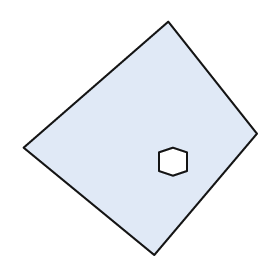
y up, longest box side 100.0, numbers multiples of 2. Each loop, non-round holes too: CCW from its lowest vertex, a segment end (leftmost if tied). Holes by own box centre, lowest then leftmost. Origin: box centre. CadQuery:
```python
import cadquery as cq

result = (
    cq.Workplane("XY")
    .moveTo(6.0, -50.0)
    .lineTo(50.0, 2.0)
    .lineTo(12.0, 50.0)
    .lineTo(-50.0, -4.0)
    .close()
    .moveTo(14.0, -16.0)
    .lineTo(20.0, -14.0)
    .lineTo(20.0, -6.0)
    .lineTo(14.0, -4.0)
    .lineTo(8.0, -6.0)
    .lineTo(8.0, -14.0)
    .close()
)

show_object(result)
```